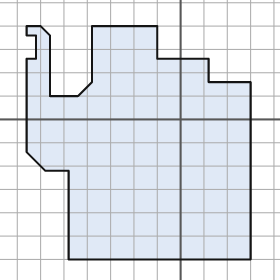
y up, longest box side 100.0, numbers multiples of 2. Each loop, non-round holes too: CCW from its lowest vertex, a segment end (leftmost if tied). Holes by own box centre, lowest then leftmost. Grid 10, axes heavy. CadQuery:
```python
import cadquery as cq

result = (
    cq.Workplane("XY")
    .moveTo(-48.0, -60.0)
    .lineTo(30.0, -60.0)
    .lineTo(30.0, 16.0)
    .lineTo(12.0, 16.0)
    .lineTo(12.0, 26.0)
    .lineTo(-10.0, 26.0)
    .lineTo(-10.0, 40.0)
    .lineTo(-38.0, 40.0)
    .lineTo(-38.0, 16.0)
    .lineTo(-44.0, 10.0)
    .lineTo(-56.0, 10.0)
    .lineTo(-56.0, 36.0)
    .lineTo(-60.0, 40.0)
    .lineTo(-66.0, 40.0)
    .lineTo(-66.0, 36.0)
    .lineTo(-62.0, 36.0)
    .lineTo(-62.0, 26.0)
    .lineTo(-66.0, 26.0)
    .lineTo(-66.0, -14.0)
    .lineTo(-58.0, -22.0)
    .lineTo(-48.0, -22.0)
    .close()
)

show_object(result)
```